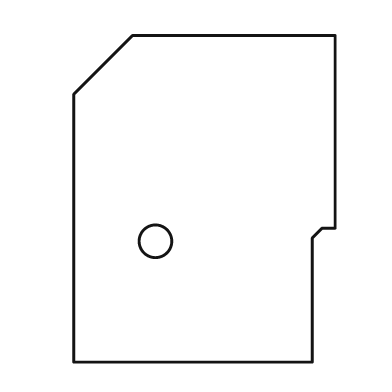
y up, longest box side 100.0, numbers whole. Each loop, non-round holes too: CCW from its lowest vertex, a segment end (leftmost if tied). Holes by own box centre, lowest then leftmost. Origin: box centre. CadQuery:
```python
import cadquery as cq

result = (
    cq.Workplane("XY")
    .moveTo(-40.0, -50.0)
    .lineTo(33.0, -50.0)
    .lineTo(33.0, -12.0)
    .lineTo(36.0, -9.0)
    .lineTo(40.0, -9.0)
    .lineTo(40.0, 50.0)
    .lineTo(-22.0, 50.0)
    .lineTo(-40.0, 32.0)
    .close()
    .moveTo(-15.0, -13.0)
    .circle(5.0)
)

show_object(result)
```